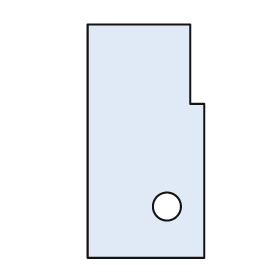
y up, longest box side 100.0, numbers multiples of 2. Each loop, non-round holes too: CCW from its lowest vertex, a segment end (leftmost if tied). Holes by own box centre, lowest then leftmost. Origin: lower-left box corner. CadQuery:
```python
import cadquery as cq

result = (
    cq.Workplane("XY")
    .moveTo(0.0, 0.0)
    .lineTo(50.0, 0.0)
    .lineTo(50.0, 66.0)
    .lineTo(44.0, 66.0)
    .lineTo(44.0, 100.0)
    .lineTo(0.0, 100.0)
    .close()
    .moveTo(34.0, 22.0)
    .circle(6.0)
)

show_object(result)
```